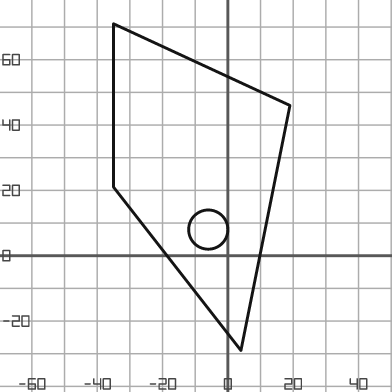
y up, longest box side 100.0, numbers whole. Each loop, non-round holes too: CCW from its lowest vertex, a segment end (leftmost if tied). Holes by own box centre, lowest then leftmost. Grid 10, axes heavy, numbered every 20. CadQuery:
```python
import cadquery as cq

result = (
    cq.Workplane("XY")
    .moveTo(4.0, -29.0)
    .lineTo(19.0, 46.0)
    .lineTo(-35.0, 71.0)
    .lineTo(-35.0, 21.0)
    .close()
    .moveTo(-6.0, 8.0)
    .circle(6.0)
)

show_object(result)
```